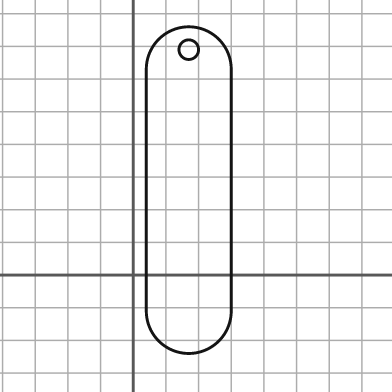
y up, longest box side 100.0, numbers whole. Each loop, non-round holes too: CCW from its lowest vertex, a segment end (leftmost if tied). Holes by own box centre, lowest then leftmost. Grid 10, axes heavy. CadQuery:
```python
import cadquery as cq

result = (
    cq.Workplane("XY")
    .moveTo(4.0, -11.0)
    .threePointArc((17.0, -24.0), (30.0, -11.0))
    .lineTo(30.0, 63.0)
    .threePointArc((17.0, 76.0), (4.0, 63.0))
    .close()
    .moveTo(17.0, 69.0)
    .circle(3.0)
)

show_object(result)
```